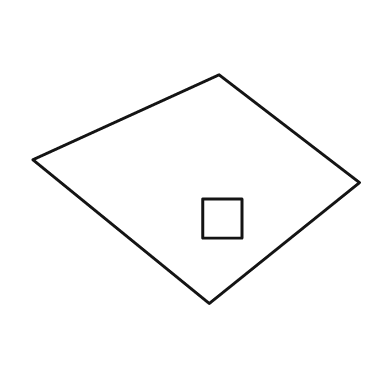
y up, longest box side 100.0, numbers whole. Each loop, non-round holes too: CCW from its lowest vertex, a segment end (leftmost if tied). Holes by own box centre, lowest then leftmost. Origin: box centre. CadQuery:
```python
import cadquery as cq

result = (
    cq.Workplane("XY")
    .moveTo(4.0, -35.0)
    .lineTo(50.0, 2.0)
    .lineTo(7.0, 35.0)
    .lineTo(-50.0, 9.0)
    .close()
    .moveTo(2.0, -15.0)
    .lineTo(14.0, -15.0)
    .lineTo(14.0, -3.0)
    .lineTo(2.0, -3.0)
    .close()
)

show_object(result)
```